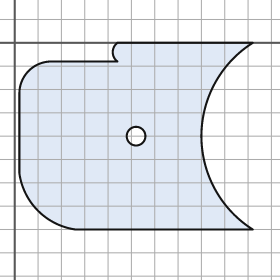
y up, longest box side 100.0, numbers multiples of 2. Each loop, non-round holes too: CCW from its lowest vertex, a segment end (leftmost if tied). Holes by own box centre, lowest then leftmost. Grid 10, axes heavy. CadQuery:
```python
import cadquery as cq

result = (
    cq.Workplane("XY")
    .moveTo(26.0, -80.0)
    .lineTo(102.0, -80.0)
    .threePointArc((80.0, -40.0), (102.0, 0.0))
    .lineTo(44.0, 0.0)
    .threePointArc((42.0, -4.0), (44.0, -8.0))
    .lineTo(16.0, -8.0)
    .threePointArc((6.0, -12.0), (2.0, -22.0))
    .lineTo(2.0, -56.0)
    .threePointArc((10.0, -72.0), (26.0, -80.0))
    .close()
    .moveTo(52.0, -40.0)
    .circle(4.0)
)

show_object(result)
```